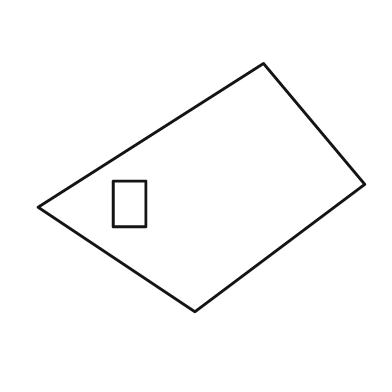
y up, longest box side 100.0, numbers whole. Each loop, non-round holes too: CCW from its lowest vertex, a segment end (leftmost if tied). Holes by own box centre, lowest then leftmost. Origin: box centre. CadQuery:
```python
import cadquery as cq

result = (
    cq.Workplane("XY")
    .moveTo(-2.0, -38.0)
    .lineTo(50.0, 1.0)
    .lineTo(19.0, 38.0)
    .lineTo(-50.0, -6.0)
    .close()
    .moveTo(-27.0, -12.0)
    .lineTo(-17.0, -12.0)
    .lineTo(-17.0, 2.0)
    .lineTo(-27.0, 2.0)
    .close()
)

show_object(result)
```